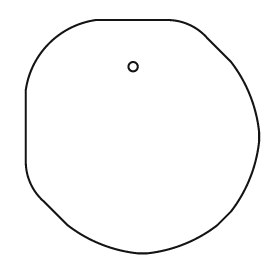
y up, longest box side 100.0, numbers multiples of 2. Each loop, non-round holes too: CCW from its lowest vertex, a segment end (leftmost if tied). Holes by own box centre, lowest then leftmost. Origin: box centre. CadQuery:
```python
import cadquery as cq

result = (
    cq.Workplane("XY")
    .moveTo(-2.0, -50.0)
    .lineTo(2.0, -50.0)
    .threePointArc((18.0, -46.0), (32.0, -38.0))
    .lineTo(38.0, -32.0)
    .threePointArc((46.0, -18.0), (50.0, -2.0))
    .lineTo(50.0, 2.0)
    .threePointArc((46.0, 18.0), (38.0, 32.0))
    .lineTo(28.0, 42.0)
    .threePointArc((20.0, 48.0), (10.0, 50.0))
    .lineTo(-20.0, 50.0)
    .threePointArc((-40.0, 40.0), (-50.0, 20.0))
    .lineTo(-50.0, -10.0)
    .threePointArc((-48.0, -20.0), (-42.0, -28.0))
    .lineTo(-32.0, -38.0)
    .threePointArc((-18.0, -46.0), (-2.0, -50.0))
    .close()
    .moveTo(-4.0, 30.0)
    .circle(2.0)
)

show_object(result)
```